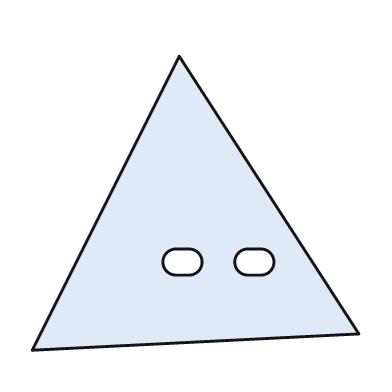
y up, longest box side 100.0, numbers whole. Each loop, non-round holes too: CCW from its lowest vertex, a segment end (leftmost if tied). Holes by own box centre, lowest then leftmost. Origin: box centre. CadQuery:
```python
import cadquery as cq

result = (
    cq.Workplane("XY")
    .moveTo(-50.0, -45.0)
    .lineTo(50.0, -40.0)
    .lineTo(-5.0, 45.0)
    .close()
    .moveTo(-6.0, -22.0)
    .lineTo(-2.0, -22.0)
    .threePointArc((2.0, -18.0), (-2.0, -14.0))
    .lineTo(-6.0, -14.0)
    .threePointArc((-10.0, -18.0), (-6.0, -22.0))
    .close()
    .moveTo(16.0, -22.0)
    .lineTo(20.0, -22.0)
    .threePointArc((24.0, -18.0), (20.0, -14.0))
    .lineTo(16.0, -14.0)
    .threePointArc((12.0, -18.0), (16.0, -22.0))
    .close()
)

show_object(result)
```